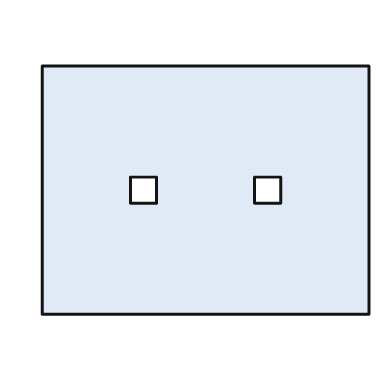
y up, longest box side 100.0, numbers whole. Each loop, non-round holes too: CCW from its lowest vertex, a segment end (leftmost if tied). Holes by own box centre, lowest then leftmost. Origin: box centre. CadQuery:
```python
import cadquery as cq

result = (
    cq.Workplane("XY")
    .moveTo(-50.0, -38.0)
    .lineTo(50.0, -38.0)
    .lineTo(50.0, 38.0)
    .lineTo(-50.0, 38.0)
    .close()
    .moveTo(-23.0, -4.0)
    .lineTo(-15.0, -4.0)
    .lineTo(-15.0, 4.0)
    .lineTo(-23.0, 4.0)
    .close()
    .moveTo(15.0, -4.0)
    .lineTo(23.0, -4.0)
    .lineTo(23.0, 4.0)
    .lineTo(15.0, 4.0)
    .close()
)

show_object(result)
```